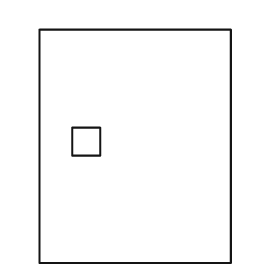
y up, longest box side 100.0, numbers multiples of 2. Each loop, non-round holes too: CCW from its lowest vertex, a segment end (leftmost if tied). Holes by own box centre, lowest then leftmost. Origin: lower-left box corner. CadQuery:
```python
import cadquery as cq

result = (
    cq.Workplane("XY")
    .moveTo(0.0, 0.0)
    .lineTo(82.0, 0.0)
    .lineTo(82.0, 100.0)
    .lineTo(0.0, 100.0)
    .close()
    .moveTo(14.0, 46.0)
    .lineTo(26.0, 46.0)
    .lineTo(26.0, 58.0)
    .lineTo(14.0, 58.0)
    .close()
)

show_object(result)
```